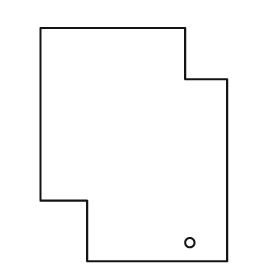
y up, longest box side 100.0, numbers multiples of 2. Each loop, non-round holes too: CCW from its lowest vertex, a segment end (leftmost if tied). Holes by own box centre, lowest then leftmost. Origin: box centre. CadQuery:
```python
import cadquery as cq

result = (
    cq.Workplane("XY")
    .moveTo(-20.0, -50.0)
    .lineTo(40.0, -50.0)
    .lineTo(40.0, 28.0)
    .lineTo(22.0, 28.0)
    .lineTo(22.0, 50.0)
    .lineTo(-40.0, 50.0)
    .lineTo(-40.0, -24.0)
    .lineTo(-20.0, -24.0)
    .close()
    .moveTo(24.0, -42.0)
    .circle(2.0)
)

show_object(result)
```